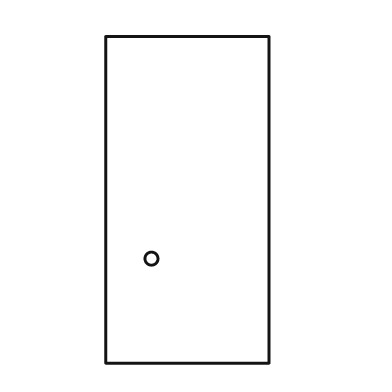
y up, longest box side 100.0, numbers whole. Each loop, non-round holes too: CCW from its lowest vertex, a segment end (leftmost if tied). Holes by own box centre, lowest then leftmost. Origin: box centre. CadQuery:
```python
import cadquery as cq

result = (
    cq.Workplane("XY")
    .moveTo(-25.0, -50.0)
    .lineTo(25.0, -50.0)
    .lineTo(25.0, 50.0)
    .lineTo(-25.0, 50.0)
    .close()
    .moveTo(-11.0, -18.0)
    .circle(2.0)
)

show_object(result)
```